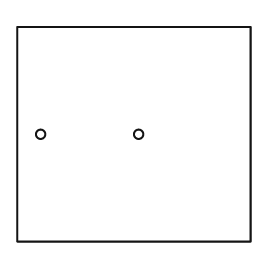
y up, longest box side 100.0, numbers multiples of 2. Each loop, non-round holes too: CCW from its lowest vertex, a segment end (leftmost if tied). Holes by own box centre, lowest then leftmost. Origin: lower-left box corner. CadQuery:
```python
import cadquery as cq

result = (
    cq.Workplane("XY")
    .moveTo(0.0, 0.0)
    .lineTo(100.0, 0.0)
    .lineTo(100.0, 92.0)
    .lineTo(0.0, 92.0)
    .close()
    .moveTo(10.0, 46.0)
    .circle(2.0)
    .moveTo(52.0, 46.0)
    .circle(2.0)
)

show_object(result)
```